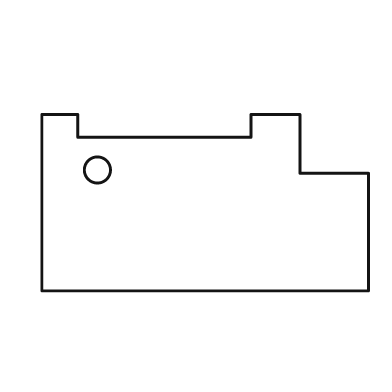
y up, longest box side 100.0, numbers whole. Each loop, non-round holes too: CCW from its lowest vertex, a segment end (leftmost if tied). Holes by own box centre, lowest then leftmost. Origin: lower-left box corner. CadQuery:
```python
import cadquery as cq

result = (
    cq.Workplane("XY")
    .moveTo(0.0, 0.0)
    .lineTo(100.0, 0.0)
    .lineTo(100.0, 36.0)
    .lineTo(79.0, 36.0)
    .lineTo(79.0, 54.0)
    .lineTo(64.0, 54.0)
    .lineTo(64.0, 47.0)
    .lineTo(11.0, 47.0)
    .lineTo(11.0, 54.0)
    .lineTo(0.0, 54.0)
    .close()
    .moveTo(17.0, 37.0)
    .circle(4.0)
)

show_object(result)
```